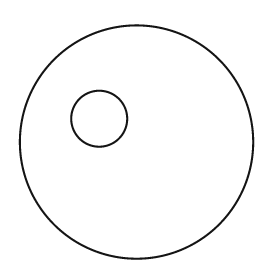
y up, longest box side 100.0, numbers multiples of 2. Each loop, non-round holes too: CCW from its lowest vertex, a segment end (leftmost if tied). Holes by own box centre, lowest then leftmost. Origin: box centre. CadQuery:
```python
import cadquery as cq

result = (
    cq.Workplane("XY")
    .moveTo(0.0, 0.0)
    .circle(50.0)
    .moveTo(-16.0, 10.0)
    .circle(12.0)
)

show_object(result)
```